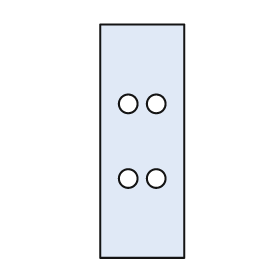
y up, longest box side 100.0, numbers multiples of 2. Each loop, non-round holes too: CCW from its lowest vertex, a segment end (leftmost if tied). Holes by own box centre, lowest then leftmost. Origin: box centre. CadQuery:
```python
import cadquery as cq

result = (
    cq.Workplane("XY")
    .moveTo(-18.0, -50.0)
    .lineTo(18.0, -50.0)
    .lineTo(18.0, 50.0)
    .lineTo(-18.0, 50.0)
    .close()
    .moveTo(-6.0, -16.0)
    .circle(4.0)
    .moveTo(6.0, -16.0)
    .circle(4.0)
    .moveTo(-6.0, 16.0)
    .circle(4.0)
    .moveTo(6.0, 16.0)
    .circle(4.0)
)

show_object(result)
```